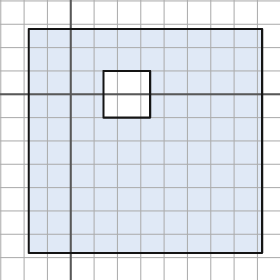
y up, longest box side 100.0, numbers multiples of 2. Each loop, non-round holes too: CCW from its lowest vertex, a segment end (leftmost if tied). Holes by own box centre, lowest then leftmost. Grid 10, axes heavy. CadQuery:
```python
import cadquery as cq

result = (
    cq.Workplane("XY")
    .moveTo(-18.0, -68.0)
    .lineTo(82.0, -68.0)
    .lineTo(82.0, 28.0)
    .lineTo(-18.0, 28.0)
    .close()
    .moveTo(14.0, -10.0)
    .lineTo(34.0, -10.0)
    .lineTo(34.0, 10.0)
    .lineTo(14.0, 10.0)
    .close()
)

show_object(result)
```